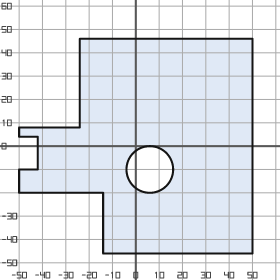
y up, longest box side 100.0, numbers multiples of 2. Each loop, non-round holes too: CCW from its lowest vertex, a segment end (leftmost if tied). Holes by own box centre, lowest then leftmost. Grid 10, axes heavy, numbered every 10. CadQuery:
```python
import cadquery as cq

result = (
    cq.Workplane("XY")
    .moveTo(-14.0, -46.0)
    .lineTo(50.0, -46.0)
    .lineTo(50.0, 46.0)
    .lineTo(-24.0, 46.0)
    .lineTo(-24.0, 8.0)
    .lineTo(-50.0, 8.0)
    .lineTo(-50.0, 4.0)
    .lineTo(-42.0, 4.0)
    .lineTo(-42.0, -10.0)
    .lineTo(-50.0, -10.0)
    .lineTo(-50.0, -20.0)
    .lineTo(-14.0, -20.0)
    .close()
    .moveTo(6.0, -10.0)
    .circle(10.0)
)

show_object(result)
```